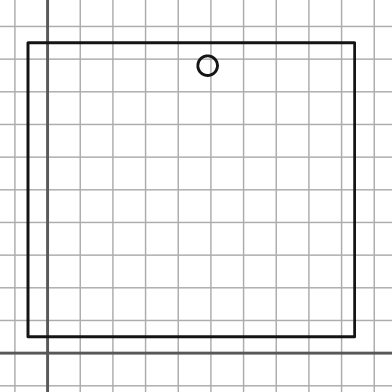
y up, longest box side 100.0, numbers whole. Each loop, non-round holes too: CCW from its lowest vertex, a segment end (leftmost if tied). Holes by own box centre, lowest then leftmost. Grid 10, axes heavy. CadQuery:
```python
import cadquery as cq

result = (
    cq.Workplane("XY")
    .moveTo(-6.0, 5.0)
    .lineTo(94.0, 5.0)
    .lineTo(94.0, 95.0)
    .lineTo(-6.0, 95.0)
    .close()
    .moveTo(49.0, 88.0)
    .circle(3.0)
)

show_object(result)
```